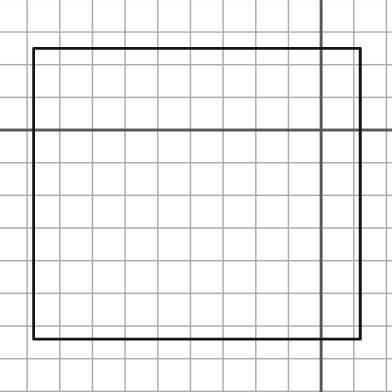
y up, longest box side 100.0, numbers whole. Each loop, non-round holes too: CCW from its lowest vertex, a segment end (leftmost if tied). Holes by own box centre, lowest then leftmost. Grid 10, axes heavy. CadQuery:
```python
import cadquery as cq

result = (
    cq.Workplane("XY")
    .moveTo(-88.0, -64.0)
    .lineTo(12.0, -64.0)
    .lineTo(12.0, 25.0)
    .lineTo(-88.0, 25.0)
    .close()
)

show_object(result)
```